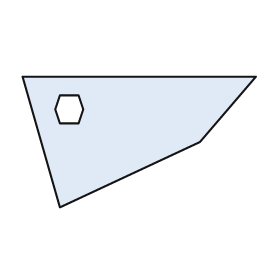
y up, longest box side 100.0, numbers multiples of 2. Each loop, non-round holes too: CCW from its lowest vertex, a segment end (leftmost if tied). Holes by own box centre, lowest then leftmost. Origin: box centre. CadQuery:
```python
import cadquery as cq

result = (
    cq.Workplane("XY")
    .moveTo(-34.0, -28.0)
    .lineTo(26.0, 0.0)
    .lineTo(50.0, 28.0)
    .lineTo(-50.0, 28.0)
    .close()
    .moveTo(-34.0, 8.0)
    .lineTo(-26.0, 8.0)
    .lineTo(-24.0, 14.0)
    .lineTo(-26.0, 20.0)
    .lineTo(-34.0, 20.0)
    .lineTo(-36.0, 14.0)
    .close()
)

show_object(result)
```